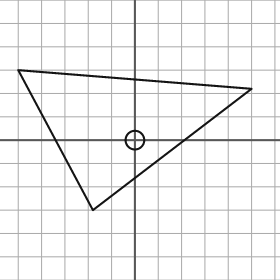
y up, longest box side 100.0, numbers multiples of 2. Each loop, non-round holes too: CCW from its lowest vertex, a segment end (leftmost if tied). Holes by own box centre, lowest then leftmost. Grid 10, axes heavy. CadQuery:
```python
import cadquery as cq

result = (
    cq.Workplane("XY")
    .moveTo(-18.0, -30.0)
    .lineTo(50.0, 22.0)
    .lineTo(-50.0, 30.0)
    .close()
    .moveTo(0.0, 0.0)
    .circle(4.0)
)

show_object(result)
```